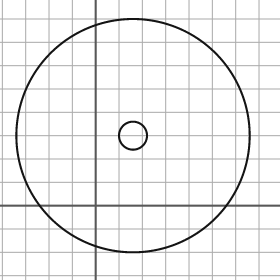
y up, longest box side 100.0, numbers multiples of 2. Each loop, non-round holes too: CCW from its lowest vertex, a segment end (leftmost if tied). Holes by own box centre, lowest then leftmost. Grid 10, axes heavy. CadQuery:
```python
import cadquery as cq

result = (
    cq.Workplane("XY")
    .moveTo(16.0, 30.0)
    .circle(50.0)
    .moveTo(16.0, 30.0)
    .circle(6.0)
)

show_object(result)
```